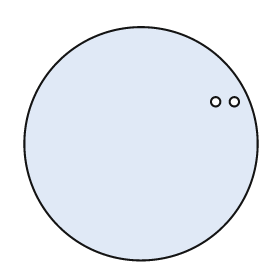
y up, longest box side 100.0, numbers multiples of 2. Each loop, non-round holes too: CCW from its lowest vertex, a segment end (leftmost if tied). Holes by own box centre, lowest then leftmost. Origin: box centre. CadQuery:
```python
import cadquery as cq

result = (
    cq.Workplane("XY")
    .moveTo(0.0, 0.0)
    .circle(50.0)
    .moveTo(32.0, 18.0)
    .circle(2.0)
    .moveTo(40.0, 18.0)
    .circle(2.0)
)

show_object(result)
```